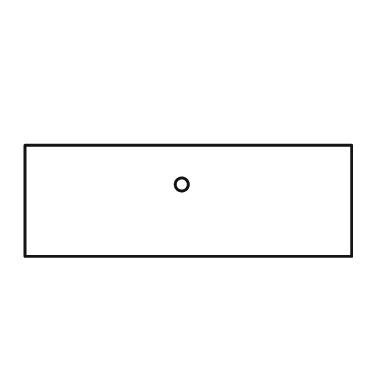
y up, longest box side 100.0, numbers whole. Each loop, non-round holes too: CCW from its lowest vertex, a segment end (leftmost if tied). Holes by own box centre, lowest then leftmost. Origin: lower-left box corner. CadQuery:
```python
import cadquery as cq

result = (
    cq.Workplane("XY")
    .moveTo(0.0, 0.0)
    .lineTo(100.0, 0.0)
    .lineTo(100.0, 34.0)
    .lineTo(0.0, 34.0)
    .close()
    .moveTo(48.0, 22.0)
    .circle(2.0)
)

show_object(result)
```